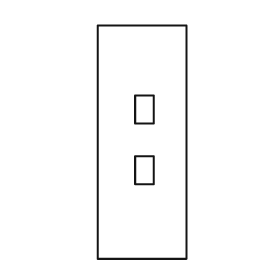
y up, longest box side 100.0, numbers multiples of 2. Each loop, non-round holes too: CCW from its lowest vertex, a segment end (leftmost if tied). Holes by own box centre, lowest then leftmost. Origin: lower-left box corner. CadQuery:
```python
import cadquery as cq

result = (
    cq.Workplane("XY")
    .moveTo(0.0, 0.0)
    .lineTo(38.0, 0.0)
    .lineTo(38.0, 100.0)
    .lineTo(0.0, 100.0)
    .close()
    .moveTo(16.0, 32.0)
    .lineTo(24.0, 32.0)
    .lineTo(24.0, 44.0)
    .lineTo(16.0, 44.0)
    .close()
    .moveTo(16.0, 58.0)
    .lineTo(24.0, 58.0)
    .lineTo(24.0, 70.0)
    .lineTo(16.0, 70.0)
    .close()
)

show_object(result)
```